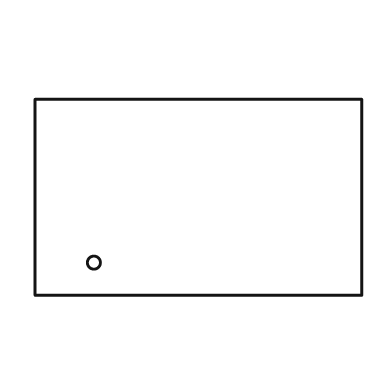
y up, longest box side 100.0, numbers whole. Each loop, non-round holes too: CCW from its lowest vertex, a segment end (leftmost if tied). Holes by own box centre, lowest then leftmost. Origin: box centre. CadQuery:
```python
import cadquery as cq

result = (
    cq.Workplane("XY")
    .moveTo(-50.0, -30.0)
    .lineTo(50.0, -30.0)
    .lineTo(50.0, 30.0)
    .lineTo(-50.0, 30.0)
    .close()
    .moveTo(-32.0, -20.0)
    .circle(2.0)
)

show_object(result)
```